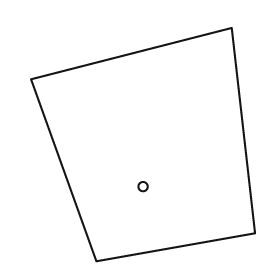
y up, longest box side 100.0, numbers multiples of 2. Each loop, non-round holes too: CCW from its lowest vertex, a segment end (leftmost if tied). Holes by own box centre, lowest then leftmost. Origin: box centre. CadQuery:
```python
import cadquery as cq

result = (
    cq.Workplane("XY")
    .moveTo(-20.0, -50.0)
    .lineTo(48.0, -38.0)
    .lineTo(38.0, 50.0)
    .lineTo(-48.0, 28.0)
    .close()
    .moveTo(0.0, -18.0)
    .circle(2.0)
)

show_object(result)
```